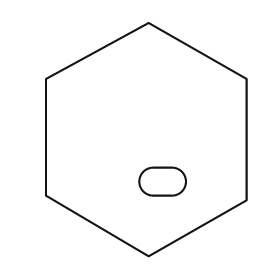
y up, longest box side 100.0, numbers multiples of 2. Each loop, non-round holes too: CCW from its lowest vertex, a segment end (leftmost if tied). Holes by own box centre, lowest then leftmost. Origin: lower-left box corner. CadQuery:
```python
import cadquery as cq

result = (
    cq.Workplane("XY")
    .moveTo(44.0, 0.0)
    .lineTo(86.0, 24.0)
    .lineTo(86.0, 76.0)
    .lineTo(44.0, 100.0)
    .lineTo(0.0, 76.0)
    .lineTo(0.0, 26.0)
    .close()
    .moveTo(46.0, 26.0)
    .lineTo(54.0, 26.0)
    .threePointArc((60.0, 32.0), (54.0, 38.0))
    .lineTo(46.0, 38.0)
    .threePointArc((40.0, 32.0), (46.0, 26.0))
    .close()
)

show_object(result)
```